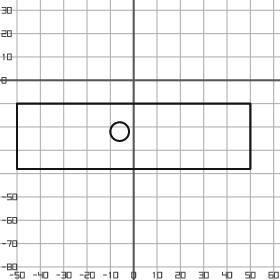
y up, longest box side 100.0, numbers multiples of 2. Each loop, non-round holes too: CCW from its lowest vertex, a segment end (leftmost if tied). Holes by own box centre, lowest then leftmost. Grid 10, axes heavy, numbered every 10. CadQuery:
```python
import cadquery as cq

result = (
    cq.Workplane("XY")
    .moveTo(-50.0, -38.0)
    .lineTo(50.0, -38.0)
    .lineTo(50.0, -10.0)
    .lineTo(-50.0, -10.0)
    .close()
    .moveTo(-6.0, -22.0)
    .circle(4.0)
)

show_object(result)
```